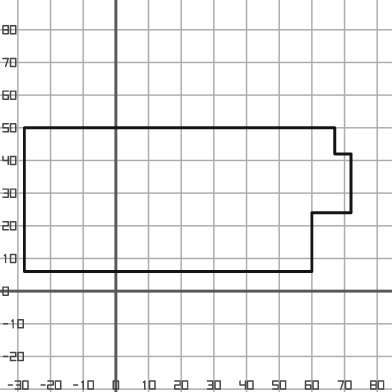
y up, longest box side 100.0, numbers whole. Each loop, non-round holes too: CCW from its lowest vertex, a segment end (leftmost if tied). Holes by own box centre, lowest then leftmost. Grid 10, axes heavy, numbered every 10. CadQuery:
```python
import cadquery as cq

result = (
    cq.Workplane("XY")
    .moveTo(-28.0, 6.0)
    .lineTo(60.0, 6.0)
    .lineTo(60.0, 24.0)
    .lineTo(72.0, 24.0)
    .lineTo(72.0, 42.0)
    .lineTo(67.0, 42.0)
    .lineTo(67.0, 50.0)
    .lineTo(-28.0, 50.0)
    .close()
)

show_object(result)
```